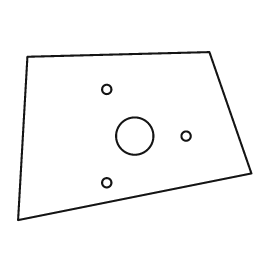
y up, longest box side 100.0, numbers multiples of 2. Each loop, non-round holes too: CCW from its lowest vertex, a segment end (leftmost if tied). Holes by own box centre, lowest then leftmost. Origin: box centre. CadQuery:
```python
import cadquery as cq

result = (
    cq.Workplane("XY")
    .moveTo(-50.0, -36.0)
    .lineTo(50.0, -16.0)
    .lineTo(32.0, 36.0)
    .lineTo(-46.0, 34.0)
    .close()
    .moveTo(-12.0, -20.0)
    .circle(2.0)
    .moveTo(0.0, 0.0)
    .circle(8.0)
    .moveTo(22.0, 0.0)
    .circle(2.0)
    .moveTo(-12.0, 20.0)
    .circle(2.0)
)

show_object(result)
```